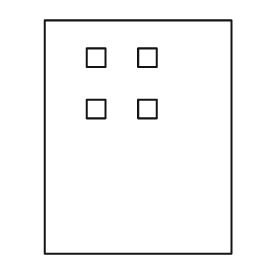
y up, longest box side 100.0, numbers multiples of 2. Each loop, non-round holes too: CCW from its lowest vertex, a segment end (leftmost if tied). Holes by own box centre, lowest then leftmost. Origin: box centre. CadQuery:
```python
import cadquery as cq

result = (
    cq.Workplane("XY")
    .moveTo(-40.0, -50.0)
    .lineTo(40.0, -50.0)
    .lineTo(40.0, 50.0)
    .lineTo(-40.0, 50.0)
    .close()
    .moveTo(-22.0, 8.0)
    .lineTo(-14.0, 8.0)
    .lineTo(-14.0, 16.0)
    .lineTo(-22.0, 16.0)
    .close()
    .moveTo(0.0, 8.0)
    .lineTo(8.0, 8.0)
    .lineTo(8.0, 16.0)
    .lineTo(0.0, 16.0)
    .close()
    .moveTo(-22.0, 30.0)
    .lineTo(-14.0, 30.0)
    .lineTo(-14.0, 38.0)
    .lineTo(-22.0, 38.0)
    .close()
    .moveTo(0.0, 30.0)
    .lineTo(8.0, 30.0)
    .lineTo(8.0, 38.0)
    .lineTo(0.0, 38.0)
    .close()
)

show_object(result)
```